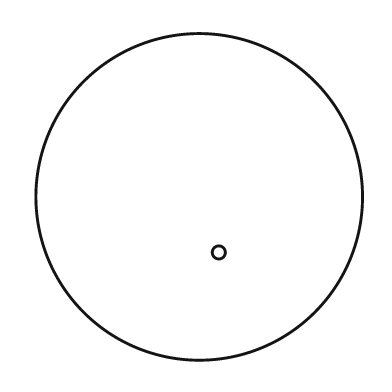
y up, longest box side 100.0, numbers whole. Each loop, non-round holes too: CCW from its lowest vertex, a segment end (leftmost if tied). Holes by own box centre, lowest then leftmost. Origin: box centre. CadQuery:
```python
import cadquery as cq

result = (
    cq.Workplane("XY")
    .moveTo(0.0, 0.0)
    .circle(50.0)
    .moveTo(6.0, -17.0)
    .circle(2.0)
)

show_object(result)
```